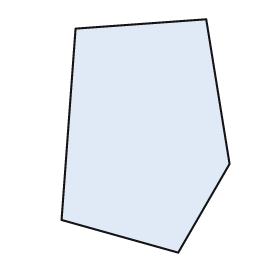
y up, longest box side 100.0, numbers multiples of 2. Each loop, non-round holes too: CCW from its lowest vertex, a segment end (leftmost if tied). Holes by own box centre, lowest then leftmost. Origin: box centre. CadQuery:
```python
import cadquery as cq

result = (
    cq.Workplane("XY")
    .moveTo(14.0, -50.0)
    .lineTo(36.0, -12.0)
    .lineTo(26.0, 50.0)
    .lineTo(-30.0, 46.0)
    .lineTo(-36.0, -36.0)
    .close()
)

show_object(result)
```